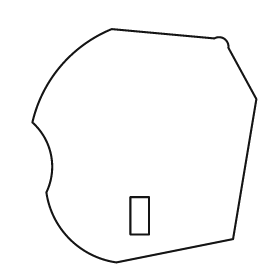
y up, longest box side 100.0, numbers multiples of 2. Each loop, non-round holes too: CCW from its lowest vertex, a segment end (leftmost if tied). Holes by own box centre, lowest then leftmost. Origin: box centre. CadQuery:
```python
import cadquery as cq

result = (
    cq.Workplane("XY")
    .moveTo(-12.0, -50.0)
    .lineTo(38.0, -40.0)
    .lineTo(48.0, 20.0)
    .lineTo(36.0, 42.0)
    .threePointArc((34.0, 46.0), (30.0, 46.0))
    .lineTo(-14.0, 50.0)
    .threePointArc((-36.0, 34.0), (-48.0, 10.0))
    .threePointArc((-40.0, -4.0), (-42.0, -20.0))
    .threePointArc((-32.0, -40.0), (-12.0, -50.0))
    .close()
    .moveTo(-6.0, -38.0)
    .lineTo(2.0, -38.0)
    .lineTo(2.0, -22.0)
    .lineTo(-6.0, -22.0)
    .close()
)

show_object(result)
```